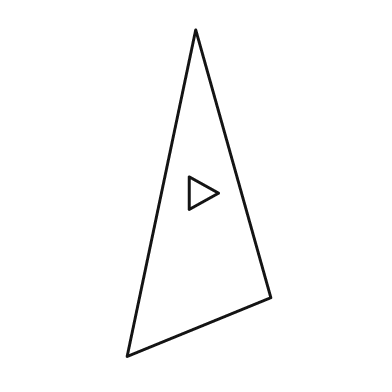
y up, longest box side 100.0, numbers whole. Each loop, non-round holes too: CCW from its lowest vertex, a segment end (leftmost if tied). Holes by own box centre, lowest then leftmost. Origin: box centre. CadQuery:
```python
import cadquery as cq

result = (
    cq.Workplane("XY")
    .moveTo(-22.0, -50.0)
    .lineTo(22.0, -32.0)
    .lineTo(-1.0, 50.0)
    .close()
    .moveTo(-3.0, -5.0)
    .lineTo(6.0, 0.0)
    .lineTo(-3.0, 5.0)
    .close()
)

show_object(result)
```